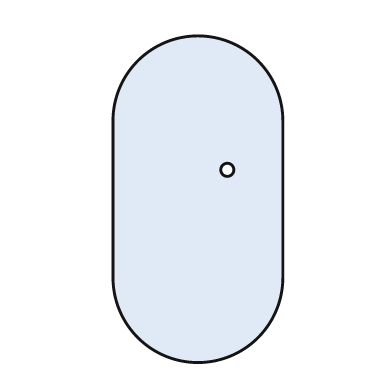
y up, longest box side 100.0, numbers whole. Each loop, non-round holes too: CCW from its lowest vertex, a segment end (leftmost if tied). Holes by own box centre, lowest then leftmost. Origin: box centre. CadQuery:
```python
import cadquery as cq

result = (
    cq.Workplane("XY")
    .moveTo(-26.0, -24.0)
    .threePointArc((0.0, -50.0), (26.0, -24.0))
    .lineTo(26.0, 24.0)
    .threePointArc((0.0, 50.0), (-26.0, 24.0))
    .close()
    .moveTo(9.0, 9.0)
    .circle(2.0)
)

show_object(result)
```